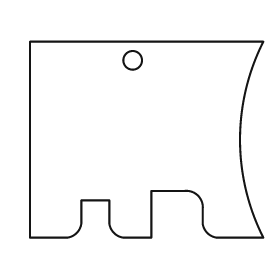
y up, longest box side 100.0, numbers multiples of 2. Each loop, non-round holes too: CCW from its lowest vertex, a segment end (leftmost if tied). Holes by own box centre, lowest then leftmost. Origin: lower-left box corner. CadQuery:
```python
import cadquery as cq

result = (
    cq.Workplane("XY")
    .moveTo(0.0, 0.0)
    .lineTo(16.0, 0.0)
    .threePointArc((20.0, 2.0), (22.0, 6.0))
    .lineTo(22.0, 16.0)
    .lineTo(34.0, 16.0)
    .lineTo(34.0, 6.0)
    .threePointArc((36.0, 2.0), (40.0, 0.0))
    .lineTo(52.0, 0.0)
    .lineTo(52.0, 20.0)
    .lineTo(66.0, 20.0)
    .threePointArc((72.0, 18.0), (74.0, 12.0))
    .lineTo(74.0, 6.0)
    .threePointArc((76.0, 2.0), (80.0, 0.0))
    .lineTo(100.0, 0.0)
    .threePointArc((90.0, 42.0), (100.0, 84.0))
    .lineTo(0.0, 84.0)
    .close()
    .moveTo(44.0, 76.0)
    .circle(4.0)
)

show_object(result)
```